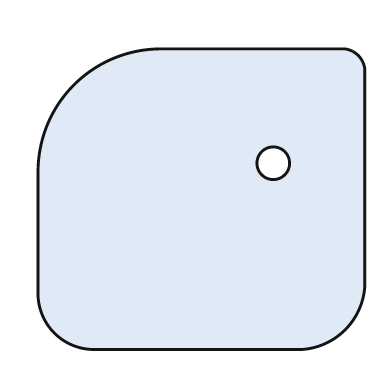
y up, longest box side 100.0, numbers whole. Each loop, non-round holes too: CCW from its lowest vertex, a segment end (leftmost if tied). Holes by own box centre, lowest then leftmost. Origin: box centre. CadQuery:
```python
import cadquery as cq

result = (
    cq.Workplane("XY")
    .moveTo(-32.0, -46.0)
    .lineTo(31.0, -46.0)
    .threePointArc((44.0, -40.0), (50.0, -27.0))
    .lineTo(50.0, 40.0)
    .threePointArc((48.0, 44.0), (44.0, 46.0))
    .lineTo(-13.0, 46.0)
    .threePointArc((-39.0, 35.0), (-50.0, 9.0))
    .lineTo(-50.0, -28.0)
    .threePointArc((-45.0, -41.0), (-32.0, -46.0))
    .close()
    .moveTo(22.0, 11.0)
    .circle(5.0)
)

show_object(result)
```